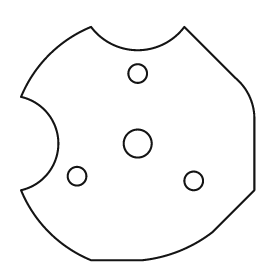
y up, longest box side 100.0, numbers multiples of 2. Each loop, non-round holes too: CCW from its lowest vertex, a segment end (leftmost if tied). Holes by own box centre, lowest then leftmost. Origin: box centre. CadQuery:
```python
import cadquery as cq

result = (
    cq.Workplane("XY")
    .moveTo(-20.0, -50.0)
    .lineTo(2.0, -50.0)
    .threePointArc((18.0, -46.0), (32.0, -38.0))
    .lineTo(50.0, -20.0)
    .lineTo(50.0, 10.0)
    .threePointArc((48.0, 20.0), (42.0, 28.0))
    .lineTo(20.0, 50.0)
    .threePointArc((0.0, 40.0), (-20.0, 50.0))
    .threePointArc((-38.0, 38.0), (-50.0, 20.0))
    .threePointArc((-34.0, 0.0), (-50.0, -20.0))
    .threePointArc((-38.0, -38.0), (-20.0, -50.0))
    .close()
    .moveTo(24.0, -16.0)
    .circle(4.0)
    .moveTo(-26.0, -14.0)
    .circle(4.0)
    .moveTo(0.0, 0.0)
    .circle(6.0)
    .moveTo(0.0, 30.0)
    .circle(4.0)
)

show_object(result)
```